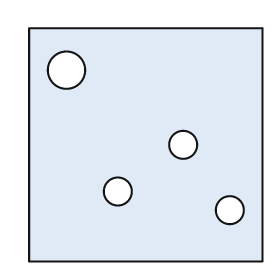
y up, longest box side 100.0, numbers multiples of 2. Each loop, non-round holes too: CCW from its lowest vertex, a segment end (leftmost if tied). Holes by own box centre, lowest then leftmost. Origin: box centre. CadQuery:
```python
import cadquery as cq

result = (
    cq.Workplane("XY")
    .moveTo(-50.0, -50.0)
    .lineTo(50.0, -50.0)
    .lineTo(50.0, 50.0)
    .lineTo(-50.0, 50.0)
    .close()
    .moveTo(36.0, -28.0)
    .circle(6.0)
    .moveTo(-12.0, -20.0)
    .circle(6.0)
    .moveTo(16.0, 0.0)
    .circle(6.0)
    .moveTo(-34.0, 32.0)
    .circle(8.0)
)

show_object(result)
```